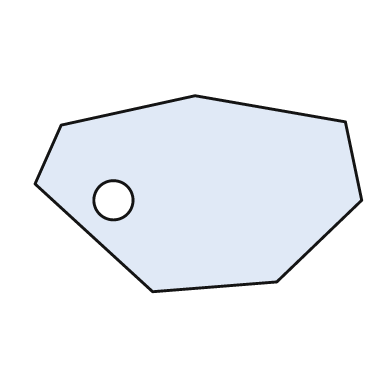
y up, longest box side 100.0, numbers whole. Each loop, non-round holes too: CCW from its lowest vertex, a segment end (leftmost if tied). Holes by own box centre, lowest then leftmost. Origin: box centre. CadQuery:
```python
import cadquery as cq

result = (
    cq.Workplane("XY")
    .moveTo(-14.0, -30.0)
    .lineTo(24.0, -27.0)
    .lineTo(50.0, -2.0)
    .lineTo(45.0, 22.0)
    .lineTo(-1.0, 30.0)
    .lineTo(-42.0, 21.0)
    .lineTo(-50.0, 3.0)
    .close()
    .moveTo(-26.0, -2.0)
    .circle(6.0)
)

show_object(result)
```